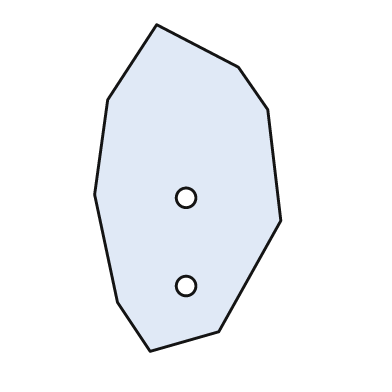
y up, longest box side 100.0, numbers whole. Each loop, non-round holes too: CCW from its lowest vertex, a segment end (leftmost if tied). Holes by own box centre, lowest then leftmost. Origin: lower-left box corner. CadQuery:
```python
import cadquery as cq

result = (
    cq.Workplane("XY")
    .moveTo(17.0, 0.0)
    .lineTo(38.0, 6.0)
    .lineTo(57.0, 40.0)
    .lineTo(53.0, 74.0)
    .lineTo(44.0, 87.0)
    .lineTo(19.0, 100.0)
    .lineTo(4.0, 77.0)
    .lineTo(0.0, 48.0)
    .lineTo(7.0, 15.0)
    .close()
    .moveTo(28.0, 20.0)
    .circle(3.0)
    .moveTo(28.0, 47.0)
    .circle(3.0)
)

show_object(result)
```